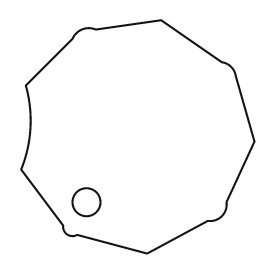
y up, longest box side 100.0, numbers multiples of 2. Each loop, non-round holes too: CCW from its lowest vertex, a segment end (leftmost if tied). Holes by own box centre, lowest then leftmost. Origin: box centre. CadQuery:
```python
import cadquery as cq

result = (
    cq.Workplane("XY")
    .moveTo(4.0, -50.0)
    .lineTo(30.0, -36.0)
    .threePointArc((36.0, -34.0), (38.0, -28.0))
    .lineTo(50.0, -2.0)
    .lineTo(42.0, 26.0)
    .threePointArc((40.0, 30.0), (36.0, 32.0))
    .lineTo(10.0, 50.0)
    .lineTo(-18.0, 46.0)
    .threePointArc((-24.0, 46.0), (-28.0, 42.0))
    .lineTo(-48.0, 22.0)
    .threePointArc((-46.0, 4.0), (-50.0, -14.0))
    .lineTo(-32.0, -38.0)
    .threePointArc((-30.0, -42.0), (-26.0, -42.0))
    .close()
    .moveTo(-22.0, -28.0)
    .circle(6.0)
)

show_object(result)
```